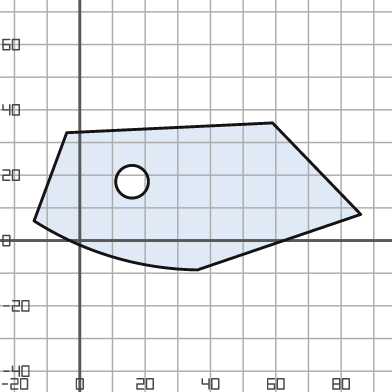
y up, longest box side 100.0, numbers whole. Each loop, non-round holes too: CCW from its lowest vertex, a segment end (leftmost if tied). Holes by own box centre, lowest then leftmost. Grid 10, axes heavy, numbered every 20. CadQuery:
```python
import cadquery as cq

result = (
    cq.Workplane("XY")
    .moveTo(36.0, -9.0)
    .lineTo(86.0, 8.0)
    .lineTo(59.0, 36.0)
    .lineTo(-4.0, 33.0)
    .lineTo(-14.0, 6.0)
    .threePointArc((10.0, -5.0), (36.0, -9.0))
    .close()
    .moveTo(16.0, 18.0)
    .circle(5.0)
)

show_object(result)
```